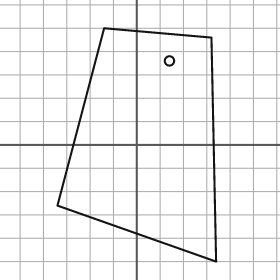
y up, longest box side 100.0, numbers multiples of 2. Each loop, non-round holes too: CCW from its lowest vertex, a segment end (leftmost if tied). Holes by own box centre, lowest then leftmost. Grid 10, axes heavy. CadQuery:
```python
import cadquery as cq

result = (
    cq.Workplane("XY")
    .moveTo(34.0, -50.0)
    .lineTo(32.0, 46.0)
    .lineTo(-14.0, 50.0)
    .lineTo(-34.0, -26.0)
    .close()
    .moveTo(14.0, 36.0)
    .circle(2.0)
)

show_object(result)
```